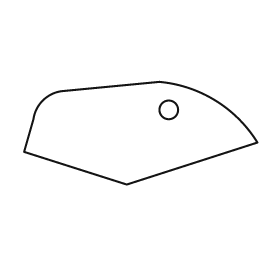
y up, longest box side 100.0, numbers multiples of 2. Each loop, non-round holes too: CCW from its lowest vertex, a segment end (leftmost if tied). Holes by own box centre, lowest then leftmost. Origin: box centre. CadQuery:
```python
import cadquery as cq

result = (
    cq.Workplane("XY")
    .moveTo(-6.0, -22.0)
    .lineTo(50.0, -4.0)
    .threePointArc((32.0, 14.0), (8.0, 22.0))
    .lineTo(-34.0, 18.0)
    .threePointArc((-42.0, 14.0), (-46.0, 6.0))
    .lineTo(-50.0, -8.0)
    .close()
    .moveTo(12.0, 10.0)
    .circle(4.0)
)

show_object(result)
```